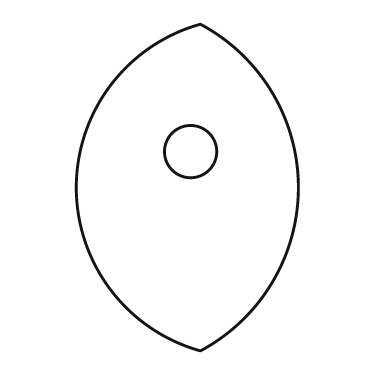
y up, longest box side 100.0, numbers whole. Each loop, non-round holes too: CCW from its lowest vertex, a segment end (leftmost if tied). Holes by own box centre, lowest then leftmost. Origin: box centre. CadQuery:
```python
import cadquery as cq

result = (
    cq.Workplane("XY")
    .moveTo(4.0, -50.0)
    .threePointArc((34.0, 0.0), (4.0, 50.0))
    .threePointArc((-34.0, 0.0), (4.0, -50.0))
    .close()
    .moveTo(1.0, 11.0)
    .circle(8.0)
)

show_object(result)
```